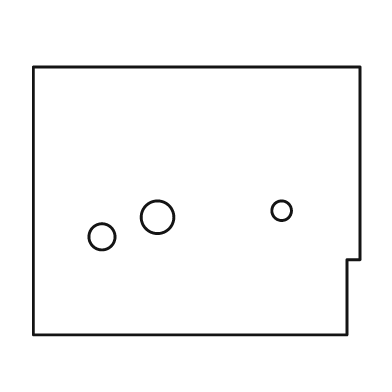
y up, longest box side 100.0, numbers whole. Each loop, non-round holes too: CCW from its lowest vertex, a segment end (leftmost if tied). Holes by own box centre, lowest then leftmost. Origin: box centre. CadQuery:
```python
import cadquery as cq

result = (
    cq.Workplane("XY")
    .moveTo(-50.0, -41.0)
    .lineTo(46.0, -41.0)
    .lineTo(46.0, -18.0)
    .lineTo(50.0, -18.0)
    .lineTo(50.0, 41.0)
    .lineTo(-50.0, 41.0)
    .close()
    .moveTo(-29.0, -11.0)
    .circle(4.0)
    .moveTo(-12.0, -5.0)
    .circle(5.0)
    .moveTo(26.0, -3.0)
    .circle(3.0)
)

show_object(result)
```